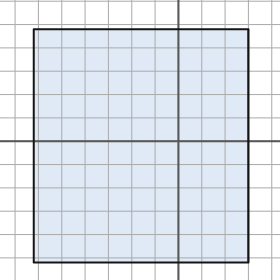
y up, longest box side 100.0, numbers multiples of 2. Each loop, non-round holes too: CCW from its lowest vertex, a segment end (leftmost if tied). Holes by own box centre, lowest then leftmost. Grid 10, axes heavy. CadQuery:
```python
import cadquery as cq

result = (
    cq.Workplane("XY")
    .moveTo(-62.0, -52.0)
    .lineTo(30.0, -52.0)
    .lineTo(30.0, 48.0)
    .lineTo(-62.0, 48.0)
    .close()
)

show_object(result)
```